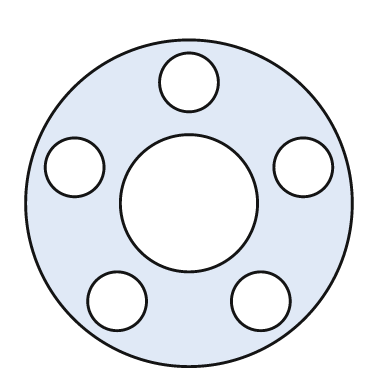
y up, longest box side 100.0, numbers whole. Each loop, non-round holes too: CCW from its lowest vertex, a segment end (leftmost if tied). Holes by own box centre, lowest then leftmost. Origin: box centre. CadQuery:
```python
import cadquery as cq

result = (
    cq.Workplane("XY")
    .moveTo(0.0, 0.0)
    .circle(50.0)
    .moveTo(-22.0, -30.0)
    .circle(9.0)
    .moveTo(22.0, -30.0)
    .circle(9.0)
    .moveTo(0.0, 0.0)
    .circle(21.0)
    .moveTo(-35.0, 11.0)
    .circle(9.0)
    .moveTo(35.0, 11.0)
    .circle(9.0)
    .moveTo(0.0, 37.0)
    .circle(9.0)
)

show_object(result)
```